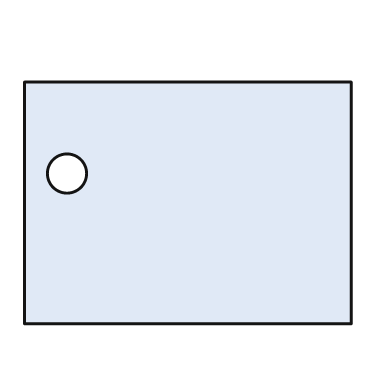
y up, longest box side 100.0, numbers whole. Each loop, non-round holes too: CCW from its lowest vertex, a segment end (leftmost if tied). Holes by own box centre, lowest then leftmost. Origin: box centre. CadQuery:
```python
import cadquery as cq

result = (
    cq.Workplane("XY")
    .moveTo(-50.0, -37.0)
    .lineTo(50.0, -37.0)
    .lineTo(50.0, 37.0)
    .lineTo(-50.0, 37.0)
    .close()
    .moveTo(-37.0, 9.0)
    .circle(6.0)
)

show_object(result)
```